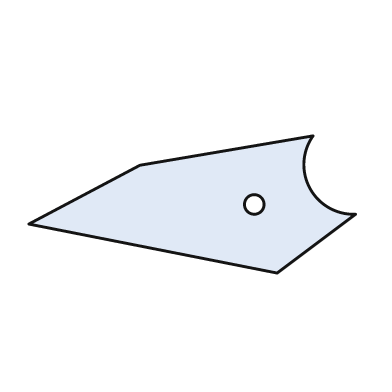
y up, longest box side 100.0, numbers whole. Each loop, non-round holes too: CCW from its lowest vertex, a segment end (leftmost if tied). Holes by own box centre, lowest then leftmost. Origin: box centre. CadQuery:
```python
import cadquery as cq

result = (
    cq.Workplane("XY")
    .moveTo(26.0, -21.0)
    .lineTo(50.0, -3.0)
    .threePointArc((36.0, 5.0), (37.0, 21.0))
    .lineTo(-16.0, 12.0)
    .lineTo(-50.0, -6.0)
    .close()
    .moveTo(19.0, 0.0)
    .circle(3.0)
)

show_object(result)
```